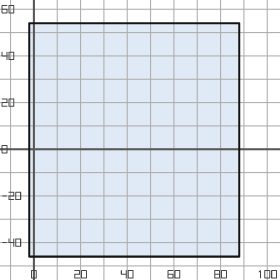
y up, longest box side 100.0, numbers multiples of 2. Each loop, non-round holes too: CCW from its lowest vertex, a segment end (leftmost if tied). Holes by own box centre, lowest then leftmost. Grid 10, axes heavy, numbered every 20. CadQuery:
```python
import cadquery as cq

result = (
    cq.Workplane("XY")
    .moveTo(-2.0, -46.0)
    .lineTo(88.0, -46.0)
    .lineTo(88.0, 54.0)
    .lineTo(-2.0, 54.0)
    .close()
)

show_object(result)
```